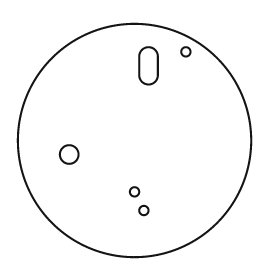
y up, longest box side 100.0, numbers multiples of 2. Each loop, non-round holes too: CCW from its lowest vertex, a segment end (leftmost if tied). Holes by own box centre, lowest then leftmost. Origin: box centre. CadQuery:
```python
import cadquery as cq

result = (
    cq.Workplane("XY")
    .moveTo(0.0, 0.0)
    .circle(50.0)
    .moveTo(4.0, -30.0)
    .circle(2.0)
    .moveTo(0.0, -22.0)
    .circle(2.0)
    .moveTo(-28.0, -6.0)
    .circle(4.0)
    .moveTo(2.0, 28.0)
    .threePointArc((6.0, 24.0), (10.0, 28.0))
    .lineTo(10.0, 36.0)
    .threePointArc((6.0, 40.0), (2.0, 36.0))
    .close()
    .moveTo(22.0, 38.0)
    .circle(2.0)
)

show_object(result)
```